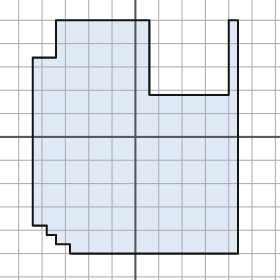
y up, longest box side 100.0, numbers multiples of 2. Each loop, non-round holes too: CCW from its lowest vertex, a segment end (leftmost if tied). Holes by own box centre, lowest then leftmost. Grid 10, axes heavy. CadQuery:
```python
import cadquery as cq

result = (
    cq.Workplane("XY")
    .moveTo(-28.0, -50.0)
    .lineTo(44.0, -50.0)
    .lineTo(44.0, 50.0)
    .lineTo(40.0, 50.0)
    .lineTo(40.0, 18.0)
    .lineTo(6.0, 18.0)
    .lineTo(6.0, 50.0)
    .lineTo(-34.0, 50.0)
    .lineTo(-34.0, 34.0)
    .lineTo(-44.0, 34.0)
    .lineTo(-44.0, -38.0)
    .lineTo(-38.0, -38.0)
    .lineTo(-38.0, -42.0)
    .lineTo(-34.0, -42.0)
    .lineTo(-34.0, -46.0)
    .lineTo(-28.0, -46.0)
    .close()
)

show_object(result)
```